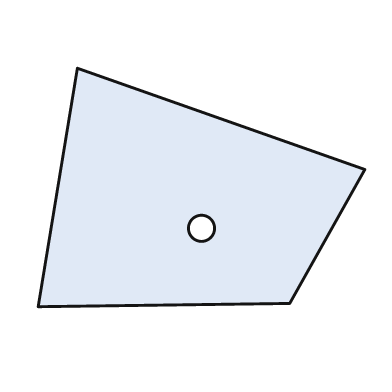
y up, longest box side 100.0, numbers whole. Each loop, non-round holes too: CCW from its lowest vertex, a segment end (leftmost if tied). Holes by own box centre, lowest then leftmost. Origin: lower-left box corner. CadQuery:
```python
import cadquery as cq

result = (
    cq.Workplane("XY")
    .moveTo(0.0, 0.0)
    .lineTo(77.0, 1.0)
    .lineTo(100.0, 42.0)
    .lineTo(12.0, 73.0)
    .close()
    .moveTo(50.0, 24.0)
    .circle(4.0)
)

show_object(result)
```